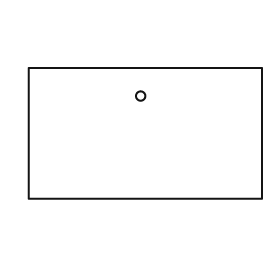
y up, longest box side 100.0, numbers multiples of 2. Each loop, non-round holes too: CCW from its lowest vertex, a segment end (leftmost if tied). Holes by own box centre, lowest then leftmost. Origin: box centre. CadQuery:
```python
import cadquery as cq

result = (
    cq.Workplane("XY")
    .moveTo(-50.0, -28.0)
    .lineTo(50.0, -28.0)
    .lineTo(50.0, 28.0)
    .lineTo(-50.0, 28.0)
    .close()
    .moveTo(-2.0, 16.0)
    .circle(2.0)
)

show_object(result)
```